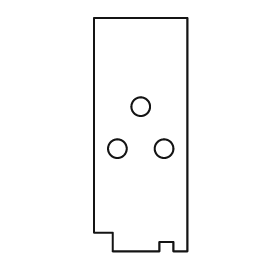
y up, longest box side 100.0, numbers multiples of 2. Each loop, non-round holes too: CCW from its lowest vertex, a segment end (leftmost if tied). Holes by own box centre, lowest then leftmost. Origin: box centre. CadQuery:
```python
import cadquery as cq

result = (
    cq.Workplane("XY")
    .moveTo(-12.0, -50.0)
    .lineTo(8.0, -50.0)
    .lineTo(8.0, -46.0)
    .lineTo(14.0, -46.0)
    .lineTo(14.0, -50.0)
    .lineTo(20.0, -50.0)
    .lineTo(20.0, 50.0)
    .lineTo(-20.0, 50.0)
    .lineTo(-20.0, -42.0)
    .lineTo(-12.0, -42.0)
    .close()
    .moveTo(-10.0, -6.0)
    .circle(4.0)
    .moveTo(10.0, -6.0)
    .circle(4.0)
    .moveTo(0.0, 12.0)
    .circle(4.0)
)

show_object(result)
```